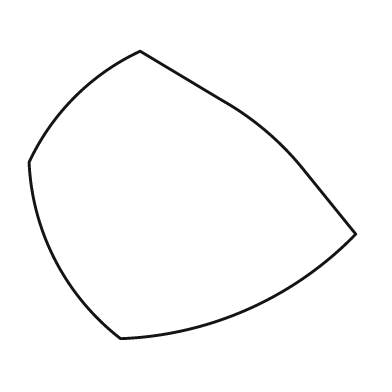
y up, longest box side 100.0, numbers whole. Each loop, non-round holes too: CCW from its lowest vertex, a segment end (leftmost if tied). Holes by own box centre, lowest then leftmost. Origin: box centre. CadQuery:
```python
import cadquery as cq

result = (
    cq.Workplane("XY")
    .moveTo(-22.0, -44.0)
    .threePointArc((17.0, -35.0), (50.0, -12.0))
    .lineTo(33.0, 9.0)
    .threePointArc((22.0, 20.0), (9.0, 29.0))
    .lineTo(-16.0, 44.0)
    .threePointArc((-36.0, 30.0), (-50.0, 10.0))
    .threePointArc((-42.0, -20.0), (-22.0, -44.0))
    .close()
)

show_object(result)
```